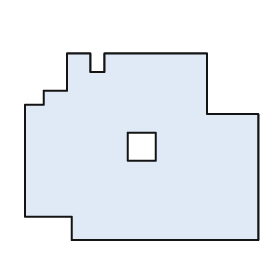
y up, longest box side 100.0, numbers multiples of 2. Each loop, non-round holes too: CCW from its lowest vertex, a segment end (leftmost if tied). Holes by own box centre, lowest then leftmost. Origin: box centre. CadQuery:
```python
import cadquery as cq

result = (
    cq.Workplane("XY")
    .moveTo(-30.0, -40.0)
    .lineTo(50.0, -40.0)
    .lineTo(50.0, 14.0)
    .lineTo(28.0, 14.0)
    .lineTo(28.0, 40.0)
    .lineTo(-16.0, 40.0)
    .lineTo(-16.0, 32.0)
    .lineTo(-22.0, 32.0)
    .lineTo(-22.0, 40.0)
    .lineTo(-32.0, 40.0)
    .lineTo(-32.0, 24.0)
    .lineTo(-42.0, 24.0)
    .lineTo(-42.0, 18.0)
    .lineTo(-50.0, 18.0)
    .lineTo(-50.0, -30.0)
    .lineTo(-30.0, -30.0)
    .close()
    .moveTo(-6.0, -6.0)
    .lineTo(6.0, -6.0)
    .lineTo(6.0, 6.0)
    .lineTo(-6.0, 6.0)
    .close()
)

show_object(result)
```